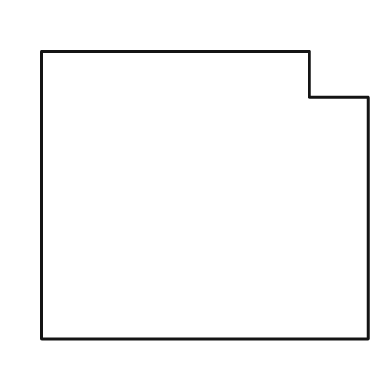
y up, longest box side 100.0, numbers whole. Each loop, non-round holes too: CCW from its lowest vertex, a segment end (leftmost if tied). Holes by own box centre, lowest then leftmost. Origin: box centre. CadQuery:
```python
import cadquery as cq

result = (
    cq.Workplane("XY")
    .moveTo(-50.0, -44.0)
    .lineTo(50.0, -44.0)
    .lineTo(50.0, 30.0)
    .lineTo(32.0, 30.0)
    .lineTo(32.0, 44.0)
    .lineTo(-50.0, 44.0)
    .close()
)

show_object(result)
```